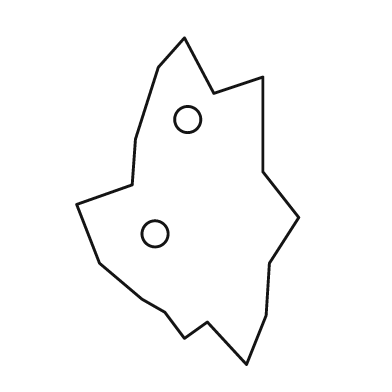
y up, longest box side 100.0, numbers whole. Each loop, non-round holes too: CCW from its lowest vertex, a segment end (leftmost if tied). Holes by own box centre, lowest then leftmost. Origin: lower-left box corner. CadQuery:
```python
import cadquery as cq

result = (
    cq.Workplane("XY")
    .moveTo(52.0, 0.0)
    .lineTo(58.0, 15.0)
    .lineTo(59.0, 31.0)
    .lineTo(68.0, 45.0)
    .lineTo(57.0, 59.0)
    .lineTo(57.0, 88.0)
    .lineTo(42.0, 83.0)
    .lineTo(33.0, 100.0)
    .lineTo(25.0, 91.0)
    .lineTo(18.0, 69.0)
    .lineTo(17.0, 55.0)
    .lineTo(0.0, 49.0)
    .lineTo(7.0, 31.0)
    .lineTo(20.0, 20.0)
    .lineTo(27.0, 16.0)
    .lineTo(33.0, 8.0)
    .lineTo(40.0, 13.0)
    .close()
    .moveTo(24.0, 40.0)
    .circle(4.0)
    .moveTo(34.0, 75.0)
    .circle(4.0)
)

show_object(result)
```